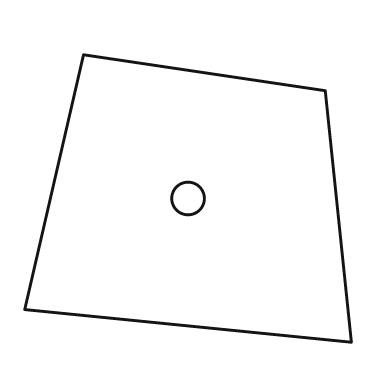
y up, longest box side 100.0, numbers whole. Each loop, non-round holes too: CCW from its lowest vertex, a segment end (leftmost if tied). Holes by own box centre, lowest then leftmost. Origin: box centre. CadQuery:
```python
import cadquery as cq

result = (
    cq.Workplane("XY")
    .moveTo(50.0, -44.0)
    .lineTo(42.0, 33.0)
    .lineTo(-32.0, 44.0)
    .lineTo(-50.0, -34.0)
    .close()
    .moveTo(0.0, 0.0)
    .circle(5.0)
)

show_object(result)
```